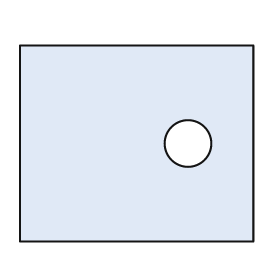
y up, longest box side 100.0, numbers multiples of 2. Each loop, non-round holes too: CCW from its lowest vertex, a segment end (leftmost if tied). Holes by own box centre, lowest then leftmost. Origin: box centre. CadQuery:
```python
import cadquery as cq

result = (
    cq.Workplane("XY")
    .moveTo(-50.0, -42.0)
    .lineTo(50.0, -42.0)
    .lineTo(50.0, 42.0)
    .lineTo(-50.0, 42.0)
    .close()
    .moveTo(22.0, 0.0)
    .circle(10.0)
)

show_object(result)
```